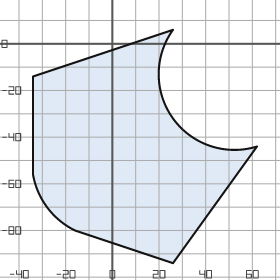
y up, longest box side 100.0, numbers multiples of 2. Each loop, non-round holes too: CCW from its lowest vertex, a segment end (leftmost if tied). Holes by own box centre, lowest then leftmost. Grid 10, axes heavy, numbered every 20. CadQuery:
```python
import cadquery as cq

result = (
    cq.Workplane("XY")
    .moveTo(26.0, -94.0)
    .lineTo(62.0, -44.0)
    .threePointArc((26.0, -32.0), (26.0, 6.0))
    .lineTo(-34.0, -14.0)
    .lineTo(-34.0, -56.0)
    .threePointArc((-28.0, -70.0), (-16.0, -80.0))
    .close()
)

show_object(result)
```